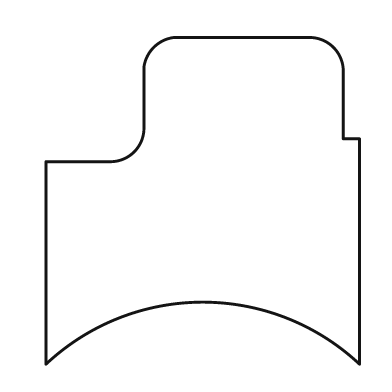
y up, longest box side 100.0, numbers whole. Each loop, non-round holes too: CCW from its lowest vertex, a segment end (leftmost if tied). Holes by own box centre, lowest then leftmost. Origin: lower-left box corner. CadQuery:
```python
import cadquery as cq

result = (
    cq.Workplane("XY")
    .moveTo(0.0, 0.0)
    .threePointArc((48.0, 19.0), (96.0, 0.0))
    .lineTo(96.0, 69.0)
    .lineTo(91.0, 69.0)
    .lineTo(91.0, 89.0)
    .threePointArc((88.0, 97.0), (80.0, 100.0))
    .lineTo(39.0, 100.0)
    .threePointArc((33.0, 97.0), (30.0, 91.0))
    .lineTo(30.0, 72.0)
    .threePointArc((27.0, 65.0), (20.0, 62.0))
    .lineTo(0.0, 62.0)
    .close()
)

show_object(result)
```